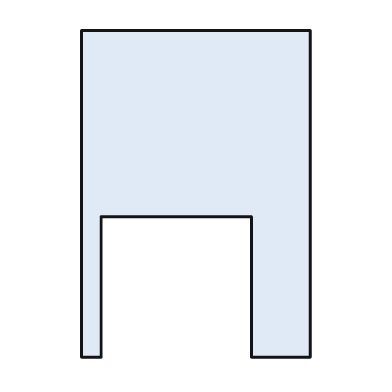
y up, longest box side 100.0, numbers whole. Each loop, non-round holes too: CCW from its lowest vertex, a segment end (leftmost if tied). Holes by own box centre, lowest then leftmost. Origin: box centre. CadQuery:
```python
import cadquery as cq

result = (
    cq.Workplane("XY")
    .moveTo(-35.0, -50.0)
    .lineTo(-29.0, -50.0)
    .lineTo(-29.0, -7.0)
    .lineTo(17.0, -7.0)
    .lineTo(17.0, -50.0)
    .lineTo(35.0, -50.0)
    .lineTo(35.0, 50.0)
    .lineTo(-35.0, 50.0)
    .close()
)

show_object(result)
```